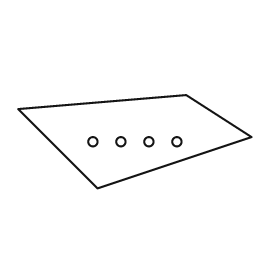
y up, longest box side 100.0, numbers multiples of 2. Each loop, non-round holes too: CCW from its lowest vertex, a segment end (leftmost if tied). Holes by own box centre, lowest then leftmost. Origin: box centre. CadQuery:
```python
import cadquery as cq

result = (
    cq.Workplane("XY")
    .moveTo(-16.0, -20.0)
    .lineTo(50.0, 2.0)
    .lineTo(22.0, 20.0)
    .lineTo(-50.0, 14.0)
    .close()
    .moveTo(-18.0, 0.0)
    .circle(2.0)
    .moveTo(-6.0, 0.0)
    .circle(2.0)
    .moveTo(6.0, 0.0)
    .circle(2.0)
    .moveTo(18.0, 0.0)
    .circle(2.0)
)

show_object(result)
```